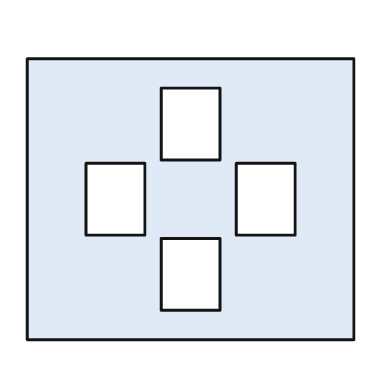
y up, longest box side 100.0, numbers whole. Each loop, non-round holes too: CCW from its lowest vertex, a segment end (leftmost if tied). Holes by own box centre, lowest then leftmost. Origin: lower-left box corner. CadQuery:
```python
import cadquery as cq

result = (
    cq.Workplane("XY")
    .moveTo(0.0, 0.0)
    .lineTo(100.0, 0.0)
    .lineTo(100.0, 86.0)
    .lineTo(0.0, 86.0)
    .close()
    .moveTo(41.0, 9.0)
    .lineTo(59.0, 9.0)
    .lineTo(59.0, 31.0)
    .lineTo(41.0, 31.0)
    .close()
    .moveTo(18.0, 32.0)
    .lineTo(36.0, 32.0)
    .lineTo(36.0, 54.0)
    .lineTo(18.0, 54.0)
    .close()
    .moveTo(64.0, 32.0)
    .lineTo(82.0, 32.0)
    .lineTo(82.0, 54.0)
    .lineTo(64.0, 54.0)
    .close()
    .moveTo(41.0, 55.0)
    .lineTo(59.0, 55.0)
    .lineTo(59.0, 77.0)
    .lineTo(41.0, 77.0)
    .close()
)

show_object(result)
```